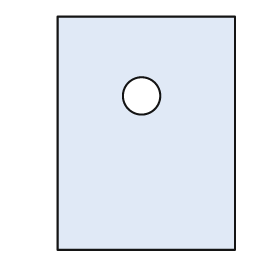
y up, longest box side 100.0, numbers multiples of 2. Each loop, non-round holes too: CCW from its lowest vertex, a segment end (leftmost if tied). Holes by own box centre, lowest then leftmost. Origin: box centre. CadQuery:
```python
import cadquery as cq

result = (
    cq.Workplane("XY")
    .moveTo(-38.0, -50.0)
    .lineTo(38.0, -50.0)
    .lineTo(38.0, 50.0)
    .lineTo(-38.0, 50.0)
    .close()
    .moveTo(-2.0, 16.0)
    .circle(8.0)
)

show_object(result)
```